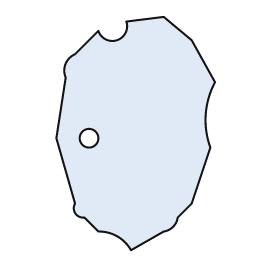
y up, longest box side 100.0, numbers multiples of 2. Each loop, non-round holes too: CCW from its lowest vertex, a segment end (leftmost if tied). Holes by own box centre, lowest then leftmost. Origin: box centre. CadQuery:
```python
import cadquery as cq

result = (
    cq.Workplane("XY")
    .moveTo(-2.0, -50.0)
    .lineTo(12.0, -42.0)
    .threePointArc((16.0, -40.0), (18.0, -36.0))
    .lineTo(24.0, -30.0)
    .lineTo(32.0, -6.0)
    .threePointArc((30.0, 8.0), (34.0, 22.0))
    .lineTo(24.0, 40.0)
    .lineTo(12.0, 50.0)
    .lineTo(-4.0, 48.0)
    .threePointArc((-8.0, 40.0), (-16.0, 44.0))
    .lineTo(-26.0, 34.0)
    .threePointArc((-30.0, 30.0), (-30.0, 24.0))
    .lineTo(-34.0, -2.0)
    .lineTo(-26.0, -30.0)
    .threePointArc((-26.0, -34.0), (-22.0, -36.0))
    .lineTo(-16.0, -42.0)
    .threePointArc((-8.0, -44.0), (-2.0, -50.0))
    .close()
    .moveTo(-20.0, -2.0)
    .circle(4.0)
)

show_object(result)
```